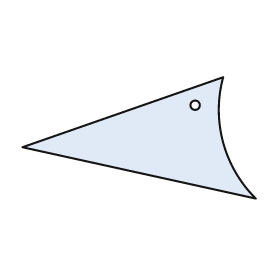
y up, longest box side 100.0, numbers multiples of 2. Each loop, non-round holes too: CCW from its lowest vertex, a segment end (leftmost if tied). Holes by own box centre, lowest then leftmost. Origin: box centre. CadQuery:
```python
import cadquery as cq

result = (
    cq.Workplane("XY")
    .moveTo(50.0, -26.0)
    .threePointArc((36.0, -2.0), (36.0, 26.0))
    .lineTo(-50.0, -4.0)
    .close()
    .moveTo(24.0, 14.0)
    .circle(2.0)
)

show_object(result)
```